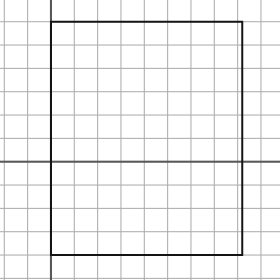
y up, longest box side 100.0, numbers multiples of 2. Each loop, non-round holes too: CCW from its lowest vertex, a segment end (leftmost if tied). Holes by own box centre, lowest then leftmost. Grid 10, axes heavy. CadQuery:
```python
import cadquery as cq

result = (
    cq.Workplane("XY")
    .moveTo(0.0, -40.0)
    .lineTo(82.0, -40.0)
    .lineTo(82.0, 60.0)
    .lineTo(0.0, 60.0)
    .close()
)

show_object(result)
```